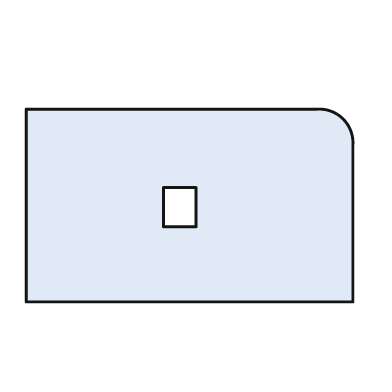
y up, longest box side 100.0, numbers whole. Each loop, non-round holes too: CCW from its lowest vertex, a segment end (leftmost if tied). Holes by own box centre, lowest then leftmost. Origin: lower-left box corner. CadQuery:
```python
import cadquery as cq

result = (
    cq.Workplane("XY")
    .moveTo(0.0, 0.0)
    .lineTo(100.0, 0.0)
    .lineTo(100.0, 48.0)
    .threePointArc((97.0, 56.0), (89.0, 59.0))
    .lineTo(0.0, 59.0)
    .close()
    .moveTo(42.0, 23.0)
    .lineTo(52.0, 23.0)
    .lineTo(52.0, 35.0)
    .lineTo(42.0, 35.0)
    .close()
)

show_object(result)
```